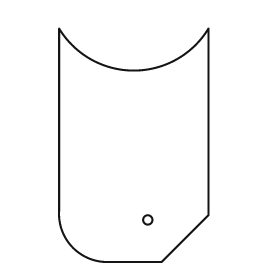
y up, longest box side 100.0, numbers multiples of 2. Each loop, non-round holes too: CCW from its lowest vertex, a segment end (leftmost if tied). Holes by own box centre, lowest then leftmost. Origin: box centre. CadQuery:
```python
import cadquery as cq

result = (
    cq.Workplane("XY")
    .moveTo(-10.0, -50.0)
    .lineTo(12.0, -50.0)
    .lineTo(32.0, -30.0)
    .lineTo(32.0, 50.0)
    .threePointArc((0.0, 32.0), (-32.0, 50.0))
    .lineTo(-32.0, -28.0)
    .threePointArc((-26.0, -44.0), (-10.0, -50.0))
    .close()
    .moveTo(6.0, -32.0)
    .circle(2.0)
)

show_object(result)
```